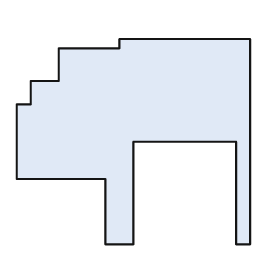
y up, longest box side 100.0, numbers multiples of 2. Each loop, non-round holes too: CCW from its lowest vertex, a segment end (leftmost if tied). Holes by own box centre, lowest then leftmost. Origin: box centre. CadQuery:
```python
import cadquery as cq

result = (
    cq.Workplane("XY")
    .moveTo(-12.0, -44.0)
    .lineTo(0.0, -44.0)
    .lineTo(0.0, 0.0)
    .lineTo(44.0, 0.0)
    .lineTo(44.0, -44.0)
    .lineTo(50.0, -44.0)
    .lineTo(50.0, 44.0)
    .lineTo(-6.0, 44.0)
    .lineTo(-6.0, 40.0)
    .lineTo(-32.0, 40.0)
    .lineTo(-32.0, 26.0)
    .lineTo(-44.0, 26.0)
    .lineTo(-44.0, 16.0)
    .lineTo(-50.0, 16.0)
    .lineTo(-50.0, -16.0)
    .lineTo(-12.0, -16.0)
    .close()
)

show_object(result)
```